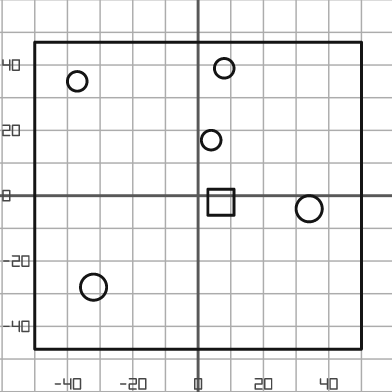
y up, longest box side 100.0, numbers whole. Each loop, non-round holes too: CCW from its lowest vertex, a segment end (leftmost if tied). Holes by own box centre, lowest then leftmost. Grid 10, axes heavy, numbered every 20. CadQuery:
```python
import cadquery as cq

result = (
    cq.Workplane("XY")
    .moveTo(-50.0, -47.0)
    .lineTo(50.0, -47.0)
    .lineTo(50.0, 47.0)
    .lineTo(-50.0, 47.0)
    .close()
    .moveTo(-32.0, -28.0)
    .circle(4.0)
    .moveTo(34.0, -4.0)
    .circle(4.0)
    .moveTo(3.0, -6.0)
    .lineTo(11.0, -6.0)
    .lineTo(11.0, 2.0)
    .lineTo(3.0, 2.0)
    .close()
    .moveTo(4.0, 17.0)
    .circle(3.0)
    .moveTo(-37.0, 35.0)
    .circle(3.0)
    .moveTo(8.0, 39.0)
    .circle(3.0)
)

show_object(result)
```